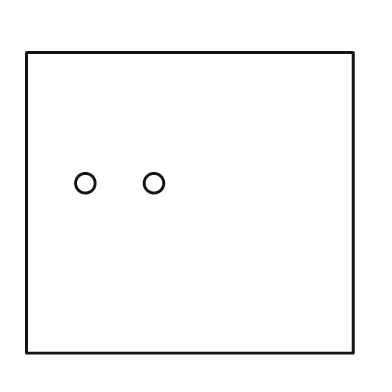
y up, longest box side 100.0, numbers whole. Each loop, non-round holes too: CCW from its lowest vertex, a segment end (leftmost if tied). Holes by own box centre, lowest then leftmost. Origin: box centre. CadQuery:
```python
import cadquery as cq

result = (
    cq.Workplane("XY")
    .moveTo(-50.0, -46.0)
    .lineTo(50.0, -46.0)
    .lineTo(50.0, 46.0)
    .lineTo(-50.0, 46.0)
    .close()
    .moveTo(-32.0, 6.0)
    .circle(3.0)
    .moveTo(-11.0, 6.0)
    .circle(3.0)
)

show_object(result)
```